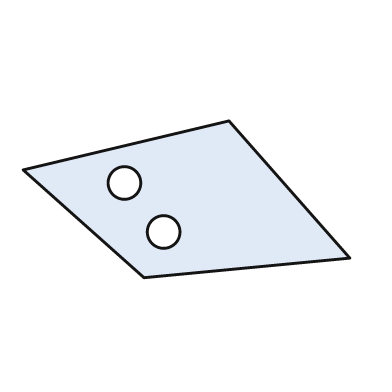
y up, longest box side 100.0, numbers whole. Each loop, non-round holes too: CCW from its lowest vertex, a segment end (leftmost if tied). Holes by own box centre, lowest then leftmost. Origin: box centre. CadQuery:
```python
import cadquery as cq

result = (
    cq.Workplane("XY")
    .moveTo(-13.0, -24.0)
    .lineTo(50.0, -18.0)
    .lineTo(13.0, 24.0)
    .lineTo(-50.0, 9.0)
    .close()
    .moveTo(-7.0, -10.0)
    .circle(5.0)
    .moveTo(-19.0, 5.0)
    .circle(5.0)
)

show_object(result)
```